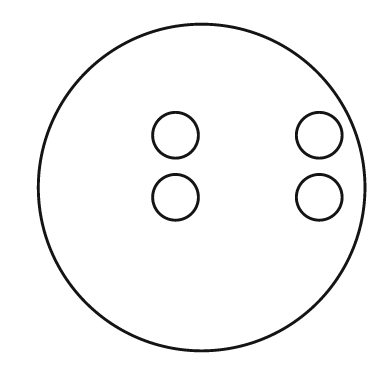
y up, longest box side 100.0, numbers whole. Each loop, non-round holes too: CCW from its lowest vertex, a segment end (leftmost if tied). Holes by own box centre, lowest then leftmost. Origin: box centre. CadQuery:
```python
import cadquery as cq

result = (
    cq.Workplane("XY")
    .moveTo(0.0, 0.0)
    .circle(50.0)
    .moveTo(-8.0, -3.0)
    .circle(7.0)
    .moveTo(36.0, -3.0)
    .circle(7.0)
    .moveTo(-8.0, 16.0)
    .circle(7.0)
    .moveTo(36.0, 16.0)
    .circle(7.0)
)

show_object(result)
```